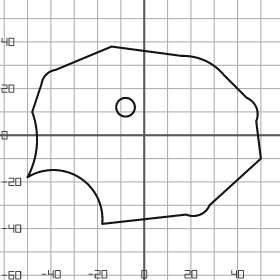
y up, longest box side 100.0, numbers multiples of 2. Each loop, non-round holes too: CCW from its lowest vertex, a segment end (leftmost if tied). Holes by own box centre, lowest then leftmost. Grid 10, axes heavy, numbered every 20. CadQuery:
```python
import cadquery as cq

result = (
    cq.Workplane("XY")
    .moveTo(-18.0, -38.0)
    .lineTo(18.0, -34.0)
    .threePointArc((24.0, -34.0), (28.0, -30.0))
    .lineTo(50.0, -10.0)
    .lineTo(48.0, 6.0)
    .threePointArc((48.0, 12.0), (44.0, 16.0))
    .lineTo(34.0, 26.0)
    .threePointArc((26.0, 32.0), (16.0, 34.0))
    .lineTo(-14.0, 38.0)
    .lineTo(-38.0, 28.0)
    .threePointArc((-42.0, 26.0), (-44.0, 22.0))
    .lineTo(-48.0, 10.0)
    .threePointArc((-46.0, -4.0), (-50.0, -18.0))
    .threePointArc((-28.0, -18.0), (-18.0, -38.0))
    .close()
    .moveTo(-8.0, 12.0)
    .circle(4.0)
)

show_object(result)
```